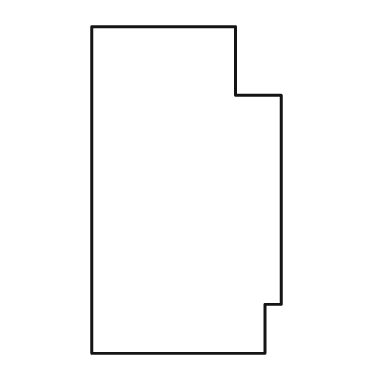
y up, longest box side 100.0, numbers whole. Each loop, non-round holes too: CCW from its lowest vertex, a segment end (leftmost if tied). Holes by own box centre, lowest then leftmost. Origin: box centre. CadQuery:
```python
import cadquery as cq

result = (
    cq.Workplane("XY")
    .moveTo(-29.0, -50.0)
    .lineTo(24.0, -50.0)
    .lineTo(24.0, -35.0)
    .lineTo(29.0, -35.0)
    .lineTo(29.0, 29.0)
    .lineTo(15.0, 29.0)
    .lineTo(15.0, 50.0)
    .lineTo(-29.0, 50.0)
    .close()
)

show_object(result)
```